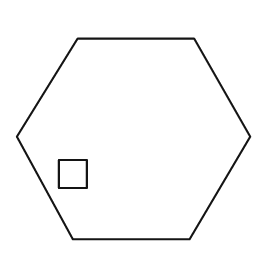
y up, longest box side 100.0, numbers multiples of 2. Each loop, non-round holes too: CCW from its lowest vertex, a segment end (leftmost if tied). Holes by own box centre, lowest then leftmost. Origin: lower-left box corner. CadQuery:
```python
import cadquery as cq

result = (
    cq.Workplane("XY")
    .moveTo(24.0, 0.0)
    .lineTo(74.0, 0.0)
    .lineTo(100.0, 44.0)
    .lineTo(76.0, 86.0)
    .lineTo(26.0, 86.0)
    .lineTo(0.0, 44.0)
    .close()
    .moveTo(18.0, 22.0)
    .lineTo(30.0, 22.0)
    .lineTo(30.0, 34.0)
    .lineTo(18.0, 34.0)
    .close()
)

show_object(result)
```